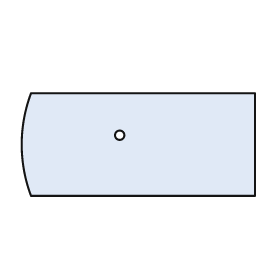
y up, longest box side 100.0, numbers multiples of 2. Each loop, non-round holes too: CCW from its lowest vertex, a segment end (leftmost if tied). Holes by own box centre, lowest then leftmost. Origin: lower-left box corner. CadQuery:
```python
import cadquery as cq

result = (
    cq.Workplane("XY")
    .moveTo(4.0, 0.0)
    .lineTo(100.0, 0.0)
    .lineTo(100.0, 44.0)
    .lineTo(4.0, 44.0)
    .threePointArc((0.0, 22.0), (4.0, 0.0))
    .close()
    .moveTo(42.0, 26.0)
    .circle(2.0)
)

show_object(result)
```